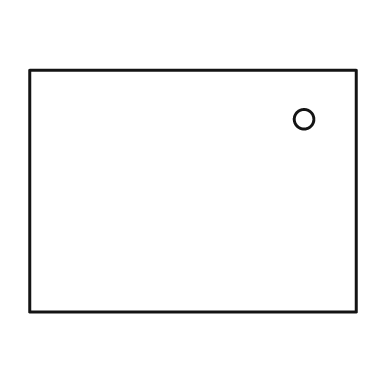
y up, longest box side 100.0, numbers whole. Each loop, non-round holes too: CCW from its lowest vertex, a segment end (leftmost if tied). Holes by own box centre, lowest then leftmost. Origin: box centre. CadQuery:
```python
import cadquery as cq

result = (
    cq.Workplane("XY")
    .moveTo(-50.0, -37.0)
    .lineTo(50.0, -37.0)
    .lineTo(50.0, 37.0)
    .lineTo(-50.0, 37.0)
    .close()
    .moveTo(34.0, 22.0)
    .circle(3.0)
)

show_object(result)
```